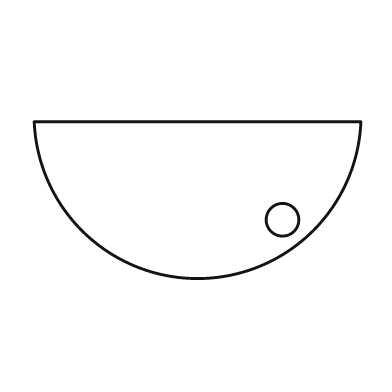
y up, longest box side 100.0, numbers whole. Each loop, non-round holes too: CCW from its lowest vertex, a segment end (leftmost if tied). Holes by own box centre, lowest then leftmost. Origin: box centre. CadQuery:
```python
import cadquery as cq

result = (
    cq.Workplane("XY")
    .moveTo(-50.0, 24.0)
    .threePointArc((0.0, -24.0), (50.0, 24.0))
    .close()
    .moveTo(26.0, -6.0)
    .circle(5.0)
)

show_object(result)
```